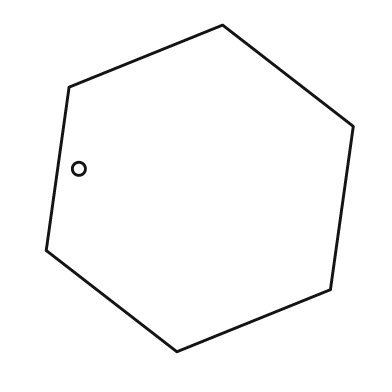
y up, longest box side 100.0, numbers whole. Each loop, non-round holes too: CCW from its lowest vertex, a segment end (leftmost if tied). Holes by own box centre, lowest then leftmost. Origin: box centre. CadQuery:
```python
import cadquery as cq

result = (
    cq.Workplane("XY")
    .moveTo(-7.0, -50.0)
    .lineTo(40.0, -31.0)
    .lineTo(47.0, 19.0)
    .lineTo(7.0, 50.0)
    .lineTo(-40.0, 31.0)
    .lineTo(-47.0, -19.0)
    .close()
    .moveTo(-37.0, 6.0)
    .circle(2.0)
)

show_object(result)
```